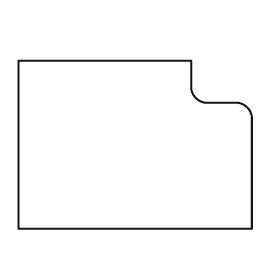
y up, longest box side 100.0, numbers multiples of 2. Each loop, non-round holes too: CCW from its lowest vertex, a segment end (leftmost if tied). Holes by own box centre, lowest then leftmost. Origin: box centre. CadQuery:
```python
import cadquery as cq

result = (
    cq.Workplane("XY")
    .moveTo(-50.0, -36.0)
    .lineTo(50.0, -36.0)
    .lineTo(50.0, 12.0)
    .threePointArc((48.0, 16.0), (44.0, 18.0))
    .lineTo(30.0, 18.0)
    .threePointArc((26.0, 20.0), (24.0, 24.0))
    .lineTo(24.0, 36.0)
    .lineTo(-50.0, 36.0)
    .close()
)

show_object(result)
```